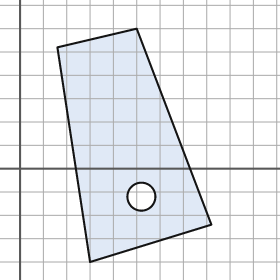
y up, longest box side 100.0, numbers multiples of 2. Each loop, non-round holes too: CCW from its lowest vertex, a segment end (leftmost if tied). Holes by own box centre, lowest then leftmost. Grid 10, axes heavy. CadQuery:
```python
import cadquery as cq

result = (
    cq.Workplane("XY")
    .moveTo(30.0, -40.0)
    .lineTo(82.0, -24.0)
    .lineTo(50.0, 60.0)
    .lineTo(16.0, 52.0)
    .close()
    .moveTo(52.0, -12.0)
    .circle(6.0)
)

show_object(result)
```